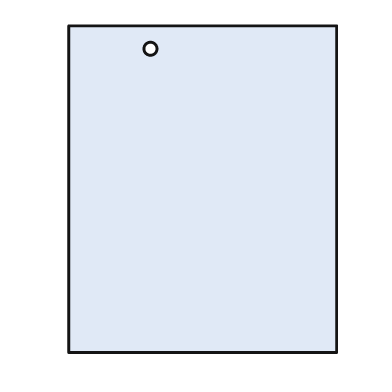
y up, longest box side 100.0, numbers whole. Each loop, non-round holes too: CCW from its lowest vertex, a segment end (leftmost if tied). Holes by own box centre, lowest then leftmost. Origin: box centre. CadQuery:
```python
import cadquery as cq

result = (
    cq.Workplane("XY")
    .moveTo(-41.0, -50.0)
    .lineTo(41.0, -50.0)
    .lineTo(41.0, 50.0)
    .lineTo(-41.0, 50.0)
    .close()
    .moveTo(-16.0, 43.0)
    .circle(2.0)
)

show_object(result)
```